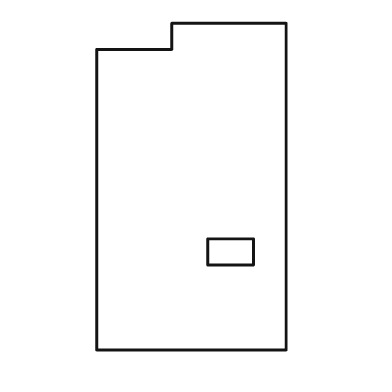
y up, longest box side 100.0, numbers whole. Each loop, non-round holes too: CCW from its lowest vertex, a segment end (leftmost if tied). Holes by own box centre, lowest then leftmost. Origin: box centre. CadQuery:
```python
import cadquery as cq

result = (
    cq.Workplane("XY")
    .moveTo(-29.0, -50.0)
    .lineTo(29.0, -50.0)
    .lineTo(29.0, 50.0)
    .lineTo(-6.0, 50.0)
    .lineTo(-6.0, 42.0)
    .lineTo(-29.0, 42.0)
    .close()
    .moveTo(5.0, -24.0)
    .lineTo(19.0, -24.0)
    .lineTo(19.0, -16.0)
    .lineTo(5.0, -16.0)
    .close()
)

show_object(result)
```